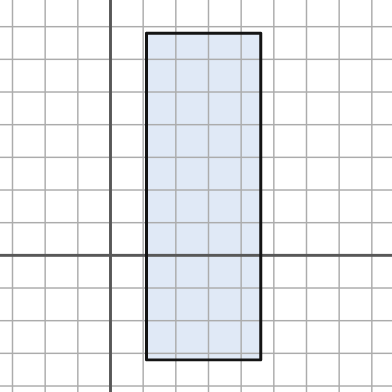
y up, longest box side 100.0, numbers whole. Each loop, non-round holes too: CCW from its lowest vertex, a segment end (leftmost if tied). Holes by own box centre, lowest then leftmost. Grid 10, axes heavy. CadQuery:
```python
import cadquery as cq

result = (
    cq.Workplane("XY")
    .moveTo(11.0, -32.0)
    .lineTo(46.0, -32.0)
    .lineTo(46.0, 68.0)
    .lineTo(11.0, 68.0)
    .close()
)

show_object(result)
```